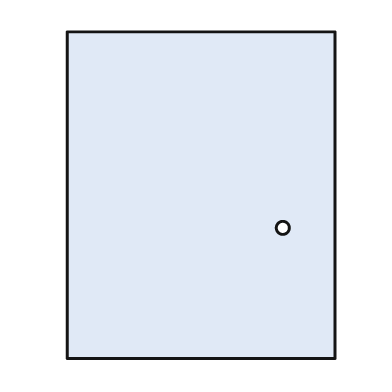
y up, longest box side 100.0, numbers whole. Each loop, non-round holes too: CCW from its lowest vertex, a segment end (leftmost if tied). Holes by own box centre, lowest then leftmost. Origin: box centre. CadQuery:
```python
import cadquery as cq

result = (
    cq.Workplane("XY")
    .moveTo(-41.0, -50.0)
    .lineTo(41.0, -50.0)
    .lineTo(41.0, 50.0)
    .lineTo(-41.0, 50.0)
    .close()
    .moveTo(25.0, -10.0)
    .circle(2.0)
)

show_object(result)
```